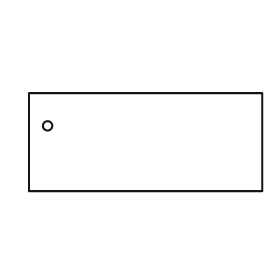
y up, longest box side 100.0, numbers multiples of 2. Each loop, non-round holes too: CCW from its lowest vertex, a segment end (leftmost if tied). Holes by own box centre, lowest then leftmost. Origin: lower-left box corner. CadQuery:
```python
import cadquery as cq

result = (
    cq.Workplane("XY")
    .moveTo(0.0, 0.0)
    .lineTo(100.0, 0.0)
    .lineTo(100.0, 42.0)
    .lineTo(0.0, 42.0)
    .close()
    .moveTo(8.0, 28.0)
    .circle(2.0)
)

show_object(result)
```